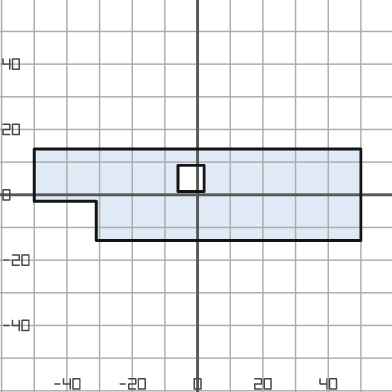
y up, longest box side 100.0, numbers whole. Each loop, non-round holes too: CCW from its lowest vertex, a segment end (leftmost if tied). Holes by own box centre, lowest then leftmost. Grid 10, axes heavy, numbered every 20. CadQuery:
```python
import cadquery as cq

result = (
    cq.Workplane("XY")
    .moveTo(-31.0, -14.0)
    .lineTo(50.0, -14.0)
    .lineTo(50.0, 14.0)
    .lineTo(-50.0, 14.0)
    .lineTo(-50.0, -2.0)
    .lineTo(-31.0, -2.0)
    .close()
    .moveTo(-6.0, 1.0)
    .lineTo(2.0, 1.0)
    .lineTo(2.0, 9.0)
    .lineTo(-6.0, 9.0)
    .close()
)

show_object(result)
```